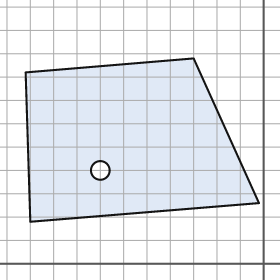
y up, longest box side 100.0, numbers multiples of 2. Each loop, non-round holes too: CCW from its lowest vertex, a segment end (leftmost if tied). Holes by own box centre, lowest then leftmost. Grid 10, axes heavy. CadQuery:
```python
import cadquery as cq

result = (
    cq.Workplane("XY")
    .moveTo(-100.0, 18.0)
    .lineTo(-2.0, 26.0)
    .lineTo(-30.0, 88.0)
    .lineTo(-102.0, 82.0)
    .close()
    .moveTo(-70.0, 40.0)
    .circle(4.0)
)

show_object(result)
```